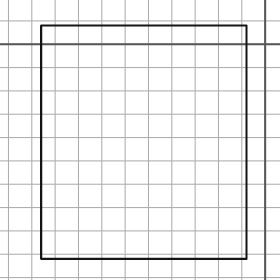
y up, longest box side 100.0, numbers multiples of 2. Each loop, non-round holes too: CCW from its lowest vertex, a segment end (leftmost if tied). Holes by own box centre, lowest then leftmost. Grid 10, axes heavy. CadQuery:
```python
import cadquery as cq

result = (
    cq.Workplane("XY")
    .moveTo(-96.0, -92.0)
    .lineTo(-8.0, -92.0)
    .lineTo(-8.0, 8.0)
    .lineTo(-96.0, 8.0)
    .close()
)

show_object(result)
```